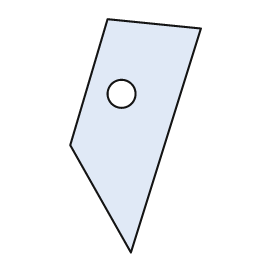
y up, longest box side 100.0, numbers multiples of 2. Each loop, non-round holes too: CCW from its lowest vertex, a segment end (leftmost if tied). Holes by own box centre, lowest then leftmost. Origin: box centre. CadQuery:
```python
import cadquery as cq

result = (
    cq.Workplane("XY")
    .moveTo(-2.0, -50.0)
    .lineTo(28.0, 46.0)
    .lineTo(-12.0, 50.0)
    .lineTo(-28.0, -4.0)
    .close()
    .moveTo(-6.0, 18.0)
    .circle(6.0)
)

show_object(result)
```